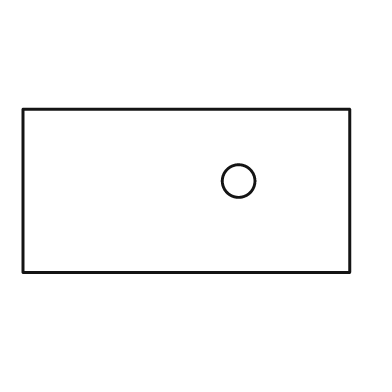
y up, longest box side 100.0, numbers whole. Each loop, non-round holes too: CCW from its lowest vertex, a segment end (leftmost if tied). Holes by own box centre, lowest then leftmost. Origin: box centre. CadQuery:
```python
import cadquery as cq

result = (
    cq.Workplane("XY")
    .moveTo(-50.0, -25.0)
    .lineTo(50.0, -25.0)
    .lineTo(50.0, 25.0)
    .lineTo(-50.0, 25.0)
    .close()
    .moveTo(16.0, 3.0)
    .circle(5.0)
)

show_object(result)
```